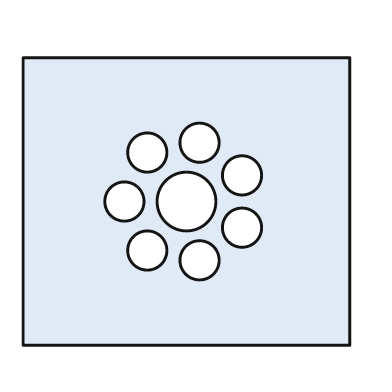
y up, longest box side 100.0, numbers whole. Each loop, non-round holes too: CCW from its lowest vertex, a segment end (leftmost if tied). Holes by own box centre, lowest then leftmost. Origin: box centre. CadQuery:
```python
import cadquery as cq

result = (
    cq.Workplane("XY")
    .moveTo(-50.0, -44.0)
    .lineTo(50.0, -44.0)
    .lineTo(50.0, 44.0)
    .lineTo(-50.0, 44.0)
    .close()
    .moveTo(4.0, -18.0)
    .circle(6.0)
    .moveTo(-12.0, -15.0)
    .circle(6.0)
    .moveTo(17.0, -8.0)
    .circle(6.0)
    .moveTo(-19.0, 0.0)
    .circle(6.0)
    .moveTo(0.0, 0.0)
    .circle(9.0)
    .moveTo(17.0, 8.0)
    .circle(6.0)
    .moveTo(-12.0, 15.0)
    .circle(6.0)
    .moveTo(4.0, 18.0)
    .circle(6.0)
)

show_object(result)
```